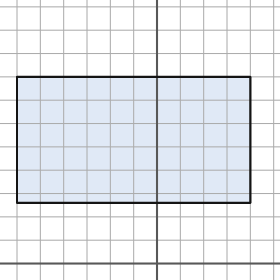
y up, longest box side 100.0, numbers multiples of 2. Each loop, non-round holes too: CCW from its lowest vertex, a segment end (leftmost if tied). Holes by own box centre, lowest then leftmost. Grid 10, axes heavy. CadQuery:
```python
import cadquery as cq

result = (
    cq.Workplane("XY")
    .moveTo(-60.0, 26.0)
    .lineTo(40.0, 26.0)
    .lineTo(40.0, 80.0)
    .lineTo(-60.0, 80.0)
    .close()
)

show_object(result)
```